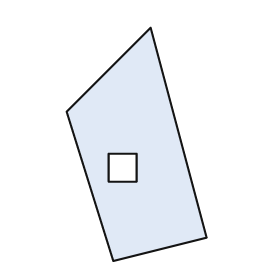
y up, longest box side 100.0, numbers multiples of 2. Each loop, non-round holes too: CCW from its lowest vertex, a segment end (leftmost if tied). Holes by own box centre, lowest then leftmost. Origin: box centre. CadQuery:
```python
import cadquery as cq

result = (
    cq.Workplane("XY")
    .moveTo(-10.0, -50.0)
    .lineTo(30.0, -40.0)
    .lineTo(6.0, 50.0)
    .lineTo(-30.0, 14.0)
    .close()
    .moveTo(-12.0, -16.0)
    .lineTo(0.0, -16.0)
    .lineTo(0.0, -4.0)
    .lineTo(-12.0, -4.0)
    .close()
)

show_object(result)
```